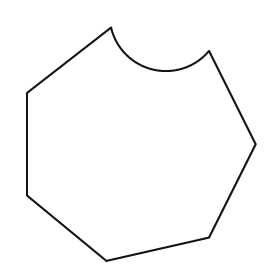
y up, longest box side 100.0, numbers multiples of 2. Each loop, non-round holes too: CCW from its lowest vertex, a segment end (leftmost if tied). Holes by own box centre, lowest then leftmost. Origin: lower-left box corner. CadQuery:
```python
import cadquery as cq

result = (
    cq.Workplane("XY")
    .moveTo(34.0, 0.0)
    .lineTo(78.0, 10.0)
    .lineTo(98.0, 50.0)
    .lineTo(78.0, 90.0)
    .threePointArc((54.0, 82.0), (36.0, 100.0))
    .lineTo(0.0, 72.0)
    .lineTo(0.0, 28.0)
    .close()
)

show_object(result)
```